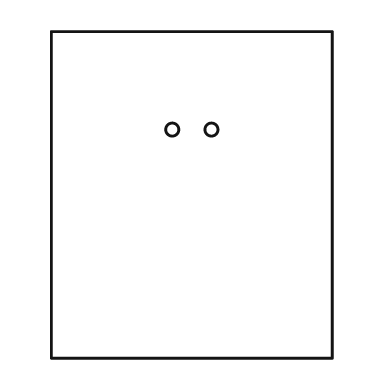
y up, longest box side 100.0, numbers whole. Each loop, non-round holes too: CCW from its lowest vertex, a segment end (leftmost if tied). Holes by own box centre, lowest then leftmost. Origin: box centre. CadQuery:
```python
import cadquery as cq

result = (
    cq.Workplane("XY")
    .moveTo(-43.0, -50.0)
    .lineTo(43.0, -50.0)
    .lineTo(43.0, 50.0)
    .lineTo(-43.0, 50.0)
    .close()
    .moveTo(-6.0, 20.0)
    .circle(2.0)
    .moveTo(6.0, 20.0)
    .circle(2.0)
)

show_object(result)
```